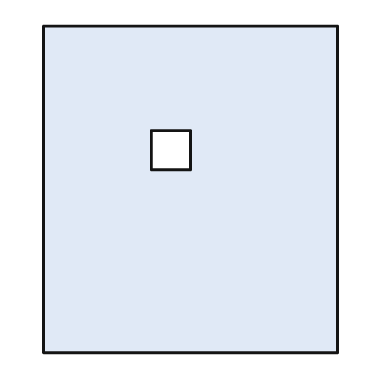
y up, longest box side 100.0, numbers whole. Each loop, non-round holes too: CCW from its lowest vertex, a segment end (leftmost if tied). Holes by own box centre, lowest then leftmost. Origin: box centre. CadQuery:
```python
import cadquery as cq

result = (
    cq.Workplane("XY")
    .moveTo(-45.0, -50.0)
    .lineTo(45.0, -50.0)
    .lineTo(45.0, 50.0)
    .lineTo(-45.0, 50.0)
    .close()
    .moveTo(-12.0, 6.0)
    .lineTo(0.0, 6.0)
    .lineTo(0.0, 18.0)
    .lineTo(-12.0, 18.0)
    .close()
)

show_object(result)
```